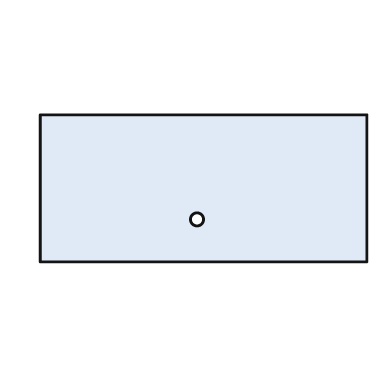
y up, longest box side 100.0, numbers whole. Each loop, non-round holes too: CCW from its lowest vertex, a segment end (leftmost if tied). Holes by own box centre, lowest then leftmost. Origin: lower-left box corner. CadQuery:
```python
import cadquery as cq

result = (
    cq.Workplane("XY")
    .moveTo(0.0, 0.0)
    .lineTo(100.0, 0.0)
    .lineTo(100.0, 45.0)
    .lineTo(0.0, 45.0)
    .close()
    .moveTo(48.0, 13.0)
    .circle(2.0)
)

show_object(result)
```